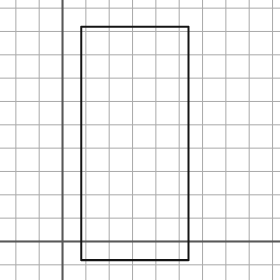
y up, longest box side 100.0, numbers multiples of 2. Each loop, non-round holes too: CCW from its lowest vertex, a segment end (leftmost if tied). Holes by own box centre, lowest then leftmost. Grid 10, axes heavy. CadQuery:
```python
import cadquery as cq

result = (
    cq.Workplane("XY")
    .moveTo(8.0, -8.0)
    .lineTo(54.0, -8.0)
    .lineTo(54.0, 92.0)
    .lineTo(8.0, 92.0)
    .close()
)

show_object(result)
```